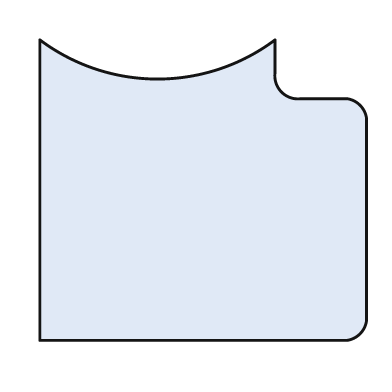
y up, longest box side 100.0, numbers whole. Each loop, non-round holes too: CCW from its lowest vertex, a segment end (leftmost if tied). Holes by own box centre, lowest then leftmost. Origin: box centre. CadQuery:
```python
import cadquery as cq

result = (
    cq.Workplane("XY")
    .moveTo(-50.0, -46.0)
    .lineTo(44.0, -46.0)
    .threePointArc((48.0, -44.0), (50.0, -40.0))
    .lineTo(50.0, 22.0)
    .threePointArc((48.0, 26.0), (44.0, 28.0))
    .lineTo(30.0, 28.0)
    .threePointArc((24.0, 30.0), (22.0, 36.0))
    .lineTo(22.0, 46.0)
    .threePointArc((-14.0, 34.0), (-50.0, 46.0))
    .close()
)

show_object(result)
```